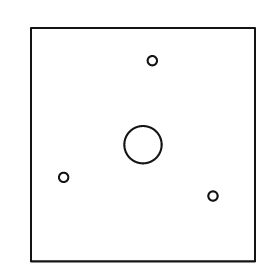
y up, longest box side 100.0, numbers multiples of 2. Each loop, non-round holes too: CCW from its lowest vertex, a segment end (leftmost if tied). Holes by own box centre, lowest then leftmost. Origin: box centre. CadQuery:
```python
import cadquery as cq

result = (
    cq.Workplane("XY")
    .moveTo(-48.0, -50.0)
    .lineTo(48.0, -50.0)
    .lineTo(48.0, 50.0)
    .lineTo(-48.0, 50.0)
    .close()
    .moveTo(30.0, -22.0)
    .circle(2.0)
    .moveTo(-34.0, -14.0)
    .circle(2.0)
    .moveTo(0.0, 0.0)
    .circle(8.0)
    .moveTo(4.0, 36.0)
    .circle(2.0)
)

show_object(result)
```